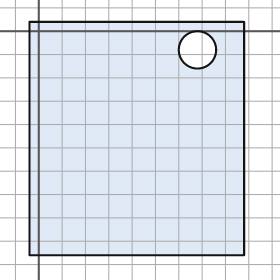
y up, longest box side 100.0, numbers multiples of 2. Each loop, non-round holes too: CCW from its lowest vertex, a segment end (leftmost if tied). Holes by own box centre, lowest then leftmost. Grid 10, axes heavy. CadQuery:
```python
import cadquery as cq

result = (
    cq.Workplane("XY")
    .moveTo(-4.0, -96.0)
    .lineTo(88.0, -96.0)
    .lineTo(88.0, 4.0)
    .lineTo(-4.0, 4.0)
    .close()
    .moveTo(68.0, -8.0)
    .circle(8.0)
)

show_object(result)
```